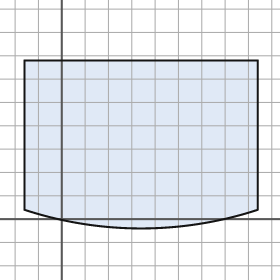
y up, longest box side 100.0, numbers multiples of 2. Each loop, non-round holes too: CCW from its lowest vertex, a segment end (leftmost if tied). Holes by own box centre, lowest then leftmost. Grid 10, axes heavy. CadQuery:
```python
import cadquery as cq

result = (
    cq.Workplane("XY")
    .moveTo(-16.0, 4.0)
    .threePointArc((34.0, -4.0), (84.0, 4.0))
    .lineTo(84.0, 68.0)
    .lineTo(-16.0, 68.0)
    .close()
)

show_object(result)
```